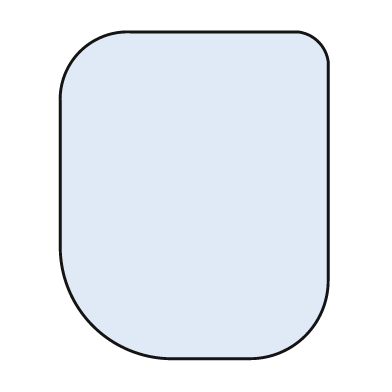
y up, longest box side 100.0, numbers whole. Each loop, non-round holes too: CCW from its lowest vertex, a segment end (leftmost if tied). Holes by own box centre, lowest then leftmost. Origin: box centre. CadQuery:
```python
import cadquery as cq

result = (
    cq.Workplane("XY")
    .moveTo(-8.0, -50.0)
    .lineTo(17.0, -50.0)
    .threePointArc((34.0, -43.0), (41.0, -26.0))
    .lineTo(41.0, 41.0)
    .threePointArc((38.0, 47.0), (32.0, 50.0))
    .lineTo(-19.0, 50.0)
    .threePointArc((-35.0, 44.0), (-41.0, 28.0))
    .lineTo(-41.0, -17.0)
    .threePointArc((-31.0, -40.0), (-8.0, -50.0))
    .close()
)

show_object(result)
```